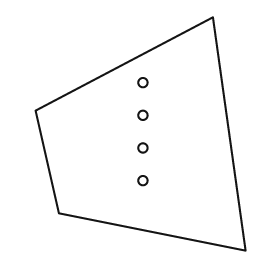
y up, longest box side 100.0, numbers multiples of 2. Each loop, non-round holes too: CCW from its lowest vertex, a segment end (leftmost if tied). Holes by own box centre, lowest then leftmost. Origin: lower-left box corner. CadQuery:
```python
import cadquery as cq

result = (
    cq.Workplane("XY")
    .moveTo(90.0, 0.0)
    .lineTo(76.0, 100.0)
    .lineTo(0.0, 60.0)
    .lineTo(10.0, 16.0)
    .close()
    .moveTo(46.0, 30.0)
    .circle(2.0)
    .moveTo(46.0, 44.0)
    .circle(2.0)
    .moveTo(46.0, 58.0)
    .circle(2.0)
    .moveTo(46.0, 72.0)
    .circle(2.0)
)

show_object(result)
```